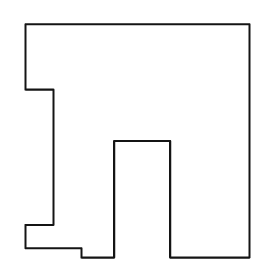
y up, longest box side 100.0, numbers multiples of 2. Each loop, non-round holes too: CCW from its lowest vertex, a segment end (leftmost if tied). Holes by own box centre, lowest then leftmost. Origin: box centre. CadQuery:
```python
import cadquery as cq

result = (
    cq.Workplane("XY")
    .moveTo(-24.0, -50.0)
    .lineTo(-10.0, -50.0)
    .lineTo(-10.0, 0.0)
    .lineTo(14.0, 0.0)
    .lineTo(14.0, -50.0)
    .lineTo(48.0, -50.0)
    .lineTo(48.0, 50.0)
    .lineTo(-48.0, 50.0)
    .lineTo(-48.0, 22.0)
    .lineTo(-36.0, 22.0)
    .lineTo(-36.0, -36.0)
    .lineTo(-48.0, -36.0)
    .lineTo(-48.0, -46.0)
    .lineTo(-24.0, -46.0)
    .close()
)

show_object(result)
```